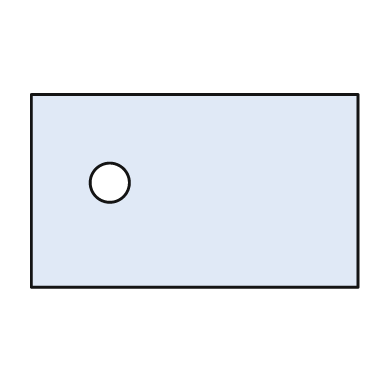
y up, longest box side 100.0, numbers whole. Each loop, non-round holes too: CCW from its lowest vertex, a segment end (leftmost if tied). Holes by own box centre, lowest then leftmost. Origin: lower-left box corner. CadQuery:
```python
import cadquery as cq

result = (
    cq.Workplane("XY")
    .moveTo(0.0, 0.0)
    .lineTo(100.0, 0.0)
    .lineTo(100.0, 59.0)
    .lineTo(0.0, 59.0)
    .close()
    .moveTo(24.0, 32.0)
    .circle(6.0)
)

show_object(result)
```